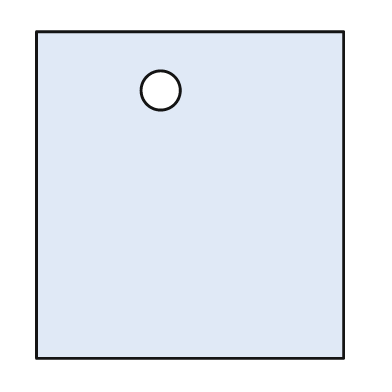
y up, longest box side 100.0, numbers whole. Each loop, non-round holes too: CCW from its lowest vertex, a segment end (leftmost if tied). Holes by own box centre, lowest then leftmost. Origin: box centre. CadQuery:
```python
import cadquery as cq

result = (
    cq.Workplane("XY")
    .moveTo(-47.0, -50.0)
    .lineTo(47.0, -50.0)
    .lineTo(47.0, 50.0)
    .lineTo(-47.0, 50.0)
    .close()
    .moveTo(-9.0, 32.0)
    .circle(6.0)
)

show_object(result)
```